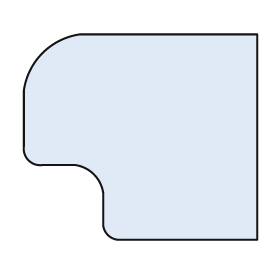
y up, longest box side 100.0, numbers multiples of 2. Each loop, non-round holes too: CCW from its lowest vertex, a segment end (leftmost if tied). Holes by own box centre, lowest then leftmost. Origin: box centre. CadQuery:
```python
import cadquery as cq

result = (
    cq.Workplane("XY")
    .moveTo(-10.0, -44.0)
    .lineTo(50.0, -44.0)
    .lineTo(50.0, 44.0)
    .lineTo(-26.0, 44.0)
    .threePointArc((-42.0, 36.0), (-50.0, 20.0))
    .lineTo(-50.0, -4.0)
    .threePointArc((-48.0, -10.0), (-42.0, -12.0))
    .lineTo(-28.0, -12.0)
    .threePointArc((-20.0, -16.0), (-16.0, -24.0))
    .lineTo(-16.0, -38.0)
    .threePointArc((-14.0, -42.0), (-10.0, -44.0))
    .close()
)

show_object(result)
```